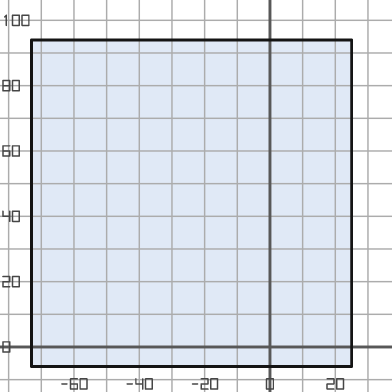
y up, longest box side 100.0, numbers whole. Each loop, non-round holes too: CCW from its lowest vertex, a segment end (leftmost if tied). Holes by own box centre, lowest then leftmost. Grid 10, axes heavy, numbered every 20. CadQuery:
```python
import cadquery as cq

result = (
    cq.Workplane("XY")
    .moveTo(-73.0, -6.0)
    .lineTo(25.0, -6.0)
    .lineTo(25.0, 94.0)
    .lineTo(-73.0, 94.0)
    .close()
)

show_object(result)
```